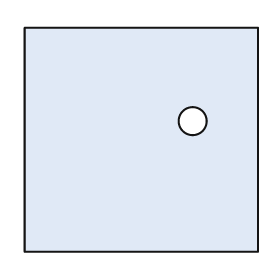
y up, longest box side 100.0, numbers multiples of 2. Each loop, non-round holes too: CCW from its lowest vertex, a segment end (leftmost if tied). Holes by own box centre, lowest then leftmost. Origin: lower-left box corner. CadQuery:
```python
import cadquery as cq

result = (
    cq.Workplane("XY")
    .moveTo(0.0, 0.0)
    .lineTo(100.0, 0.0)
    .lineTo(100.0, 96.0)
    .lineTo(0.0, 96.0)
    .close()
    .moveTo(72.0, 56.0)
    .circle(6.0)
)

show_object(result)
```